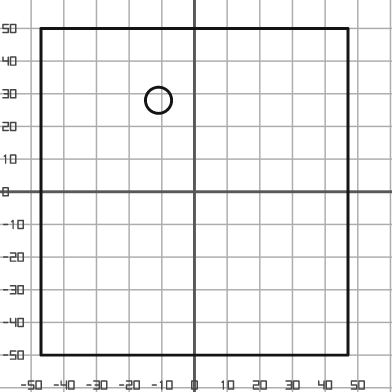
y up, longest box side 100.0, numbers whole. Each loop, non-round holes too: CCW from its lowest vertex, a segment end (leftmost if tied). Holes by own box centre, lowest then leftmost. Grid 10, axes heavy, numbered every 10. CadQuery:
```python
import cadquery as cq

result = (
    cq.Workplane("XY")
    .moveTo(-47.0, -50.0)
    .lineTo(47.0, -50.0)
    .lineTo(47.0, 50.0)
    .lineTo(-47.0, 50.0)
    .close()
    .moveTo(-11.0, 28.0)
    .circle(4.0)
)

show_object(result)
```